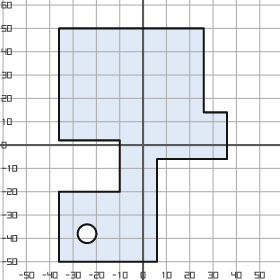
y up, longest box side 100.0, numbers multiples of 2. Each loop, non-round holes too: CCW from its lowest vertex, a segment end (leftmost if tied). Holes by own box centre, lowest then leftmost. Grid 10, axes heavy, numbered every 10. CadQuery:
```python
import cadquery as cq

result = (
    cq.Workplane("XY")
    .moveTo(-36.0, -50.0)
    .lineTo(6.0, -50.0)
    .lineTo(6.0, -6.0)
    .lineTo(36.0, -6.0)
    .lineTo(36.0, 14.0)
    .lineTo(26.0, 14.0)
    .lineTo(26.0, 50.0)
    .lineTo(-36.0, 50.0)
    .lineTo(-36.0, 2.0)
    .lineTo(-10.0, 2.0)
    .lineTo(-10.0, -20.0)
    .lineTo(-36.0, -20.0)
    .close()
    .moveTo(-24.0, -38.0)
    .circle(4.0)
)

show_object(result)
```